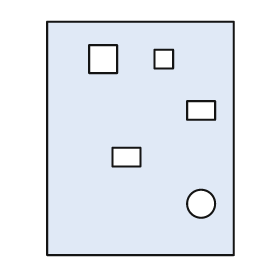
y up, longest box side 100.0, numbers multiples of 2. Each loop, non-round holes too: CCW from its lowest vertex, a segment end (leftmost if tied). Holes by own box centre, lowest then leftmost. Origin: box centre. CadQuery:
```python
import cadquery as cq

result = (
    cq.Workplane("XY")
    .moveTo(-40.0, -50.0)
    .lineTo(40.0, -50.0)
    .lineTo(40.0, 50.0)
    .lineTo(-40.0, 50.0)
    .close()
    .moveTo(26.0, -28.0)
    .circle(6.0)
    .moveTo(-12.0, -12.0)
    .lineTo(0.0, -12.0)
    .lineTo(0.0, -4.0)
    .lineTo(-12.0, -4.0)
    .close()
    .moveTo(20.0, 8.0)
    .lineTo(32.0, 8.0)
    .lineTo(32.0, 16.0)
    .lineTo(20.0, 16.0)
    .close()
    .moveTo(-22.0, 28.0)
    .lineTo(-10.0, 28.0)
    .lineTo(-10.0, 40.0)
    .lineTo(-22.0, 40.0)
    .close()
    .moveTo(6.0, 30.0)
    .lineTo(14.0, 30.0)
    .lineTo(14.0, 38.0)
    .lineTo(6.0, 38.0)
    .close()
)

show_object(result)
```